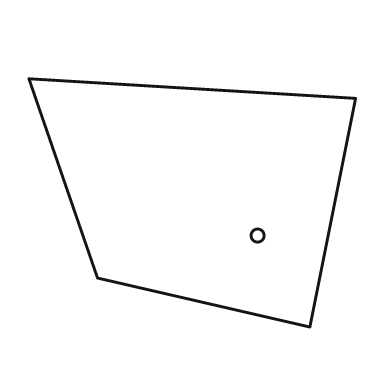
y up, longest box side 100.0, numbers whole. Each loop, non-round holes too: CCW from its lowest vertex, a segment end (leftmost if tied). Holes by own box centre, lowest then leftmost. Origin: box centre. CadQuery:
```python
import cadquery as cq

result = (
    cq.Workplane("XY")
    .moveTo(36.0, -38.0)
    .lineTo(50.0, 32.0)
    .lineTo(-50.0, 38.0)
    .lineTo(-29.0, -23.0)
    .close()
    .moveTo(20.0, -10.0)
    .circle(2.0)
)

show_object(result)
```